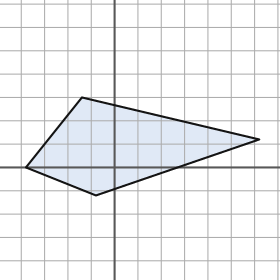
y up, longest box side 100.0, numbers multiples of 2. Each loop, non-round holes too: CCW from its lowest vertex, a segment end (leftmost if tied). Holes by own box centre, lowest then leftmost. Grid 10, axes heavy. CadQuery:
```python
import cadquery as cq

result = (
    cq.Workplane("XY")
    .moveTo(-8.0, -12.0)
    .lineTo(62.0, 12.0)
    .lineTo(-14.0, 30.0)
    .lineTo(-38.0, 0.0)
    .close()
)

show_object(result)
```